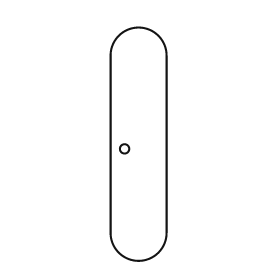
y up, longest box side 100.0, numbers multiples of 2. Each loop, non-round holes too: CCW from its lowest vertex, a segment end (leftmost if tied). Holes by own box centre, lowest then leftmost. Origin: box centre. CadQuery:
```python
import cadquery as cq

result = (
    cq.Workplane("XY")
    .moveTo(-12.0, -38.0)
    .threePointArc((0.0, -50.0), (12.0, -38.0))
    .lineTo(12.0, 38.0)
    .threePointArc((0.0, 50.0), (-12.0, 38.0))
    .close()
    .moveTo(-6.0, -2.0)
    .circle(2.0)
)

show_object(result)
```